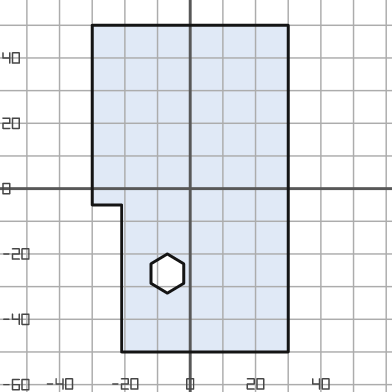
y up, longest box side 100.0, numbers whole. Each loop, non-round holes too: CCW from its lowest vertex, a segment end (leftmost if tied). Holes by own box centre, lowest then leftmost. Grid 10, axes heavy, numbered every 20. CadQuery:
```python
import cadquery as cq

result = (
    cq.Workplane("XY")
    .moveTo(-21.0, -50.0)
    .lineTo(30.0, -50.0)
    .lineTo(30.0, 50.0)
    .lineTo(-30.0, 50.0)
    .lineTo(-30.0, -5.0)
    .lineTo(-21.0, -5.0)
    .close()
    .moveTo(-7.0, -32.0)
    .lineTo(-2.0, -29.0)
    .lineTo(-2.0, -23.0)
    .lineTo(-7.0, -20.0)
    .lineTo(-12.0, -23.0)
    .lineTo(-12.0, -29.0)
    .close()
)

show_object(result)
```